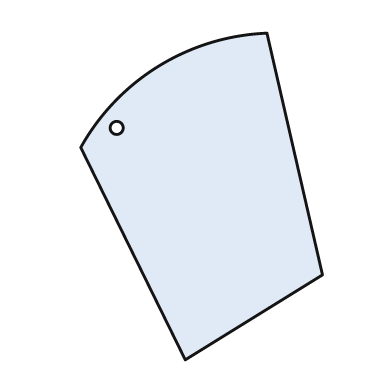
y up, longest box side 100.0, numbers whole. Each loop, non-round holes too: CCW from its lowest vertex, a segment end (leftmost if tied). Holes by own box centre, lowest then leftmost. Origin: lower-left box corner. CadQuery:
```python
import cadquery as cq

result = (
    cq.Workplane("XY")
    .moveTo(32.0, 0.0)
    .lineTo(74.0, 26.0)
    .lineTo(57.0, 100.0)
    .threePointArc((24.0, 90.0), (0.0, 65.0))
    .close()
    .moveTo(11.0, 71.0)
    .circle(2.0)
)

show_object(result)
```